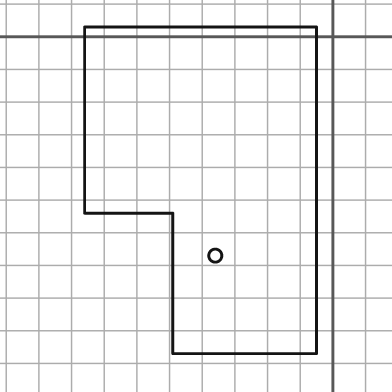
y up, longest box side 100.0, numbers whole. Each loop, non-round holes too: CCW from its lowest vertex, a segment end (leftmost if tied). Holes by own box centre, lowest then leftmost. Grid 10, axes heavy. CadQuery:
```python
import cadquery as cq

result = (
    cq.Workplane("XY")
    .moveTo(-49.0, -97.0)
    .lineTo(-5.0, -97.0)
    .lineTo(-5.0, 3.0)
    .lineTo(-76.0, 3.0)
    .lineTo(-76.0, -54.0)
    .lineTo(-49.0, -54.0)
    .close()
    .moveTo(-36.0, -67.0)
    .circle(2.0)
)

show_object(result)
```